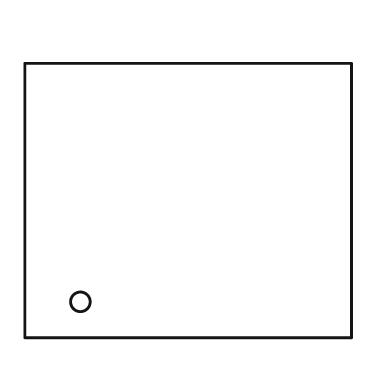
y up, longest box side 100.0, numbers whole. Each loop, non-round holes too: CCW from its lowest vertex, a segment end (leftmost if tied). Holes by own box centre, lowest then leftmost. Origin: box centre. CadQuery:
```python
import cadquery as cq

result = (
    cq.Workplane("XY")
    .moveTo(-50.0, -42.0)
    .lineTo(50.0, -42.0)
    .lineTo(50.0, 42.0)
    .lineTo(-50.0, 42.0)
    .close()
    .moveTo(-33.0, -31.0)
    .circle(3.0)
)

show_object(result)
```